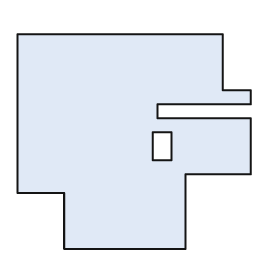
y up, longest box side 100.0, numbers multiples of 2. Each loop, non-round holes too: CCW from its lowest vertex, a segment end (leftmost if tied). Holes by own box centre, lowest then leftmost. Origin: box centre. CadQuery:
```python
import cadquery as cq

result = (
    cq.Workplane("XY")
    .moveTo(-30.0, -46.0)
    .lineTo(22.0, -46.0)
    .lineTo(22.0, -14.0)
    .lineTo(50.0, -14.0)
    .lineTo(50.0, 10.0)
    .lineTo(10.0, 10.0)
    .lineTo(10.0, 16.0)
    .lineTo(50.0, 16.0)
    .lineTo(50.0, 22.0)
    .lineTo(38.0, 22.0)
    .lineTo(38.0, 46.0)
    .lineTo(-50.0, 46.0)
    .lineTo(-50.0, -22.0)
    .lineTo(-30.0, -22.0)
    .close()
    .moveTo(8.0, -8.0)
    .lineTo(16.0, -8.0)
    .lineTo(16.0, 4.0)
    .lineTo(8.0, 4.0)
    .close()
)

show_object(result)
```